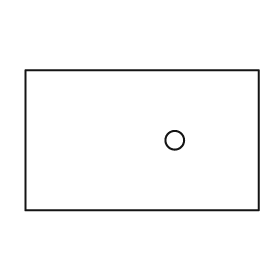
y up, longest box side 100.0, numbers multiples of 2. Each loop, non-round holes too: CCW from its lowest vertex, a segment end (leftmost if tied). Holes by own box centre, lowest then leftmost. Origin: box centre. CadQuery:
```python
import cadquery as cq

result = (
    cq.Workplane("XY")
    .moveTo(-50.0, -30.0)
    .lineTo(50.0, -30.0)
    .lineTo(50.0, 30.0)
    .lineTo(-50.0, 30.0)
    .close()
    .moveTo(14.0, 0.0)
    .circle(4.0)
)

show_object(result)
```